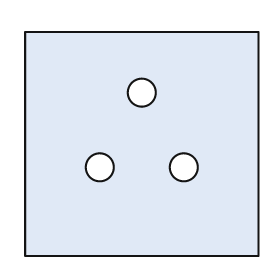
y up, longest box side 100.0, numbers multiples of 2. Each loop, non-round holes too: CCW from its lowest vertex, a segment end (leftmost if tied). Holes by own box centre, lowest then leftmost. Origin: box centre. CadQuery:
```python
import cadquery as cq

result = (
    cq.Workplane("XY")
    .moveTo(-50.0, -48.0)
    .lineTo(50.0, -48.0)
    .lineTo(50.0, 48.0)
    .lineTo(-50.0, 48.0)
    .close()
    .moveTo(-18.0, -10.0)
    .circle(6.0)
    .moveTo(18.0, -10.0)
    .circle(6.0)
    .moveTo(0.0, 22.0)
    .circle(6.0)
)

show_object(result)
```